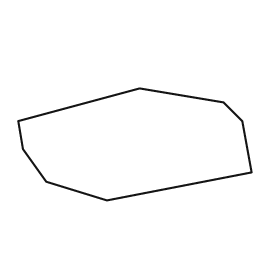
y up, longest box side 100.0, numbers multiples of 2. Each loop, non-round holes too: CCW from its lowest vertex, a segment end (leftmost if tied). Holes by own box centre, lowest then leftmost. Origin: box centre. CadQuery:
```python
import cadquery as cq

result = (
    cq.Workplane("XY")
    .moveTo(-12.0, -24.0)
    .lineTo(50.0, -12.0)
    .lineTo(46.0, 10.0)
    .lineTo(38.0, 18.0)
    .lineTo(2.0, 24.0)
    .lineTo(-50.0, 10.0)
    .lineTo(-48.0, -2.0)
    .lineTo(-38.0, -16.0)
    .close()
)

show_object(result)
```